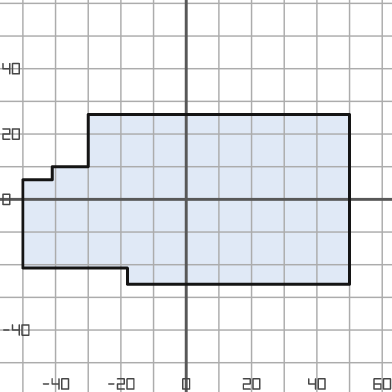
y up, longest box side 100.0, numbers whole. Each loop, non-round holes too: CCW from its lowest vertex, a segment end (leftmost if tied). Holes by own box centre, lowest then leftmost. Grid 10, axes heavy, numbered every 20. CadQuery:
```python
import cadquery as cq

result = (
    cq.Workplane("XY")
    .moveTo(-18.0, -26.0)
    .lineTo(50.0, -26.0)
    .lineTo(50.0, 26.0)
    .lineTo(-30.0, 26.0)
    .lineTo(-30.0, 10.0)
    .lineTo(-41.0, 10.0)
    .lineTo(-41.0, 6.0)
    .lineTo(-50.0, 6.0)
    .lineTo(-50.0, -21.0)
    .lineTo(-18.0, -21.0)
    .close()
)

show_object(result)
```